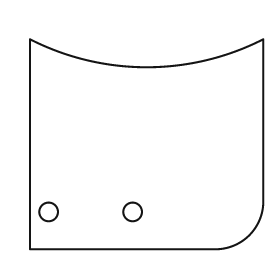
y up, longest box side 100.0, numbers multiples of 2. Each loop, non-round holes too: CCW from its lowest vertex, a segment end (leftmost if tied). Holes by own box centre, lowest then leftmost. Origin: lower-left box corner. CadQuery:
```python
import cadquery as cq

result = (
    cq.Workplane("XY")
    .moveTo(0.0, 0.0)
    .lineTo(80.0, 0.0)
    .threePointArc((94.0, 6.0), (100.0, 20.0))
    .lineTo(100.0, 90.0)
    .threePointArc((50.0, 78.0), (0.0, 90.0))
    .close()
    .moveTo(8.0, 16.0)
    .circle(4.0)
    .moveTo(44.0, 16.0)
    .circle(4.0)
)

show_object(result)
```